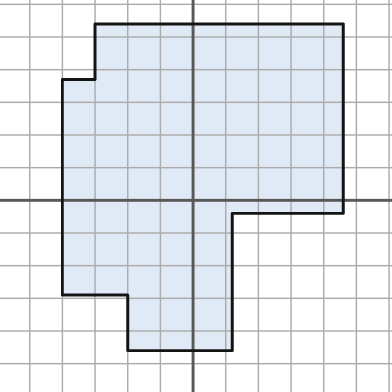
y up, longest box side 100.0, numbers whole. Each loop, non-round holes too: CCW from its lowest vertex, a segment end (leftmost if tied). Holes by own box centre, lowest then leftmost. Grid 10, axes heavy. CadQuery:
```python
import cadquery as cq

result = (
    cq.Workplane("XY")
    .moveTo(-20.0, -46.0)
    .lineTo(12.0, -46.0)
    .lineTo(12.0, -4.0)
    .lineTo(46.0, -4.0)
    .lineTo(46.0, 54.0)
    .lineTo(-30.0, 54.0)
    .lineTo(-30.0, 37.0)
    .lineTo(-40.0, 37.0)
    .lineTo(-40.0, -29.0)
    .lineTo(-20.0, -29.0)
    .close()
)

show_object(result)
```